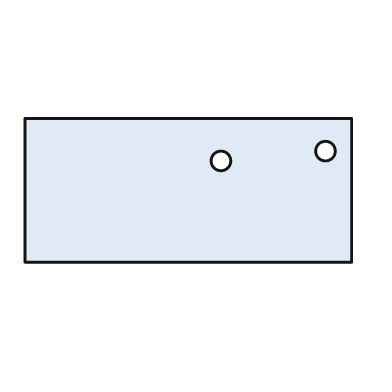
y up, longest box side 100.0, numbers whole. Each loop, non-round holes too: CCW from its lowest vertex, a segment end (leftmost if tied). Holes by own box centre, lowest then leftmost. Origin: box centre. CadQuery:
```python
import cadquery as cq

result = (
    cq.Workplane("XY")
    .moveTo(-50.0, -22.0)
    .lineTo(50.0, -22.0)
    .lineTo(50.0, 22.0)
    .lineTo(-50.0, 22.0)
    .close()
    .moveTo(10.0, 9.0)
    .circle(3.0)
    .moveTo(42.0, 12.0)
    .circle(3.0)
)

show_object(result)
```